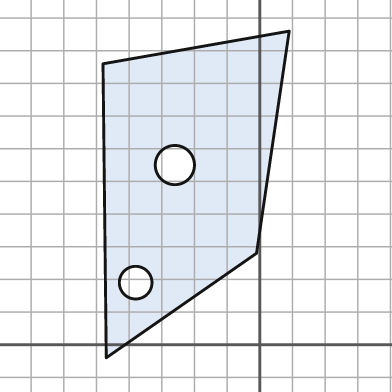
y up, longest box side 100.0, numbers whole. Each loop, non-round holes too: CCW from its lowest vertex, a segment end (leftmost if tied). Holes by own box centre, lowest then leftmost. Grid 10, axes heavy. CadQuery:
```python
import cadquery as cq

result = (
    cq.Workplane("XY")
    .moveTo(-47.0, -4.0)
    .lineTo(-1.0, 28.0)
    .lineTo(9.0, 96.0)
    .lineTo(-48.0, 86.0)
    .close()
    .moveTo(-38.0, 19.0)
    .circle(5.0)
    .moveTo(-26.0, 55.0)
    .circle(6.0)
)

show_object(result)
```